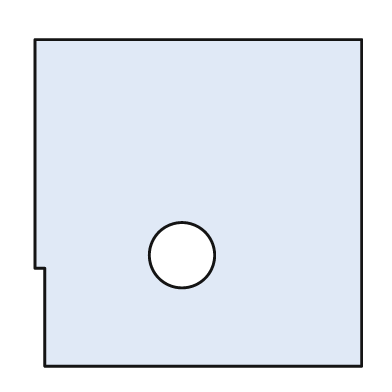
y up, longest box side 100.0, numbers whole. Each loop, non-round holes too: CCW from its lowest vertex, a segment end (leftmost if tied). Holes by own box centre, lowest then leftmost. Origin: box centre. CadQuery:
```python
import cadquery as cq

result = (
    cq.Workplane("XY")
    .moveTo(-47.0, -50.0)
    .lineTo(50.0, -50.0)
    .lineTo(50.0, 50.0)
    .lineTo(-50.0, 50.0)
    .lineTo(-50.0, -20.0)
    .lineTo(-47.0, -20.0)
    .close()
    .moveTo(-5.0, -16.0)
    .circle(10.0)
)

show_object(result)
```